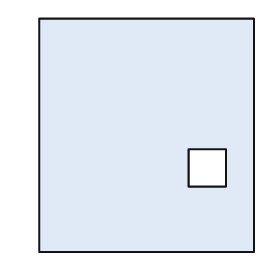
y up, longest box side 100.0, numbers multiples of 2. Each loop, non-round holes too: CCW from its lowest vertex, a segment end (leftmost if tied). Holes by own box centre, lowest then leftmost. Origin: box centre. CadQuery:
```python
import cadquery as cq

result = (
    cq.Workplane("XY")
    .moveTo(-46.0, -50.0)
    .lineTo(46.0, -50.0)
    .lineTo(46.0, 50.0)
    .lineTo(-46.0, 50.0)
    .close()
    .moveTo(18.0, -22.0)
    .lineTo(34.0, -22.0)
    .lineTo(34.0, -6.0)
    .lineTo(18.0, -6.0)
    .close()
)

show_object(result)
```